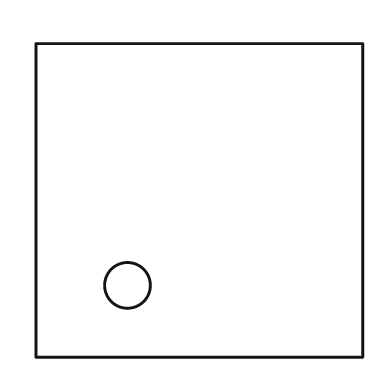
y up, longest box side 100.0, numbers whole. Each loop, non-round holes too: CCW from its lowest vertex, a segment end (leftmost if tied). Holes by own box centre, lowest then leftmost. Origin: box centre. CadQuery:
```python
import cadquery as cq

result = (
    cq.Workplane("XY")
    .moveTo(-50.0, -48.0)
    .lineTo(50.0, -48.0)
    .lineTo(50.0, 48.0)
    .lineTo(-50.0, 48.0)
    .close()
    .moveTo(-22.0, -26.0)
    .circle(7.0)
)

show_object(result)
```